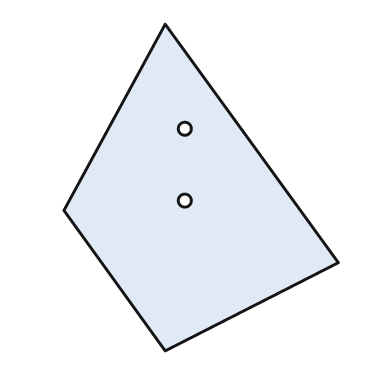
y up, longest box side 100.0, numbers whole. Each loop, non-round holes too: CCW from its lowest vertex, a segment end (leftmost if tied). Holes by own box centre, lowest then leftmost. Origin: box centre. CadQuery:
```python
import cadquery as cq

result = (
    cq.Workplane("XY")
    .moveTo(-11.0, -50.0)
    .lineTo(42.0, -23.0)
    .lineTo(-11.0, 50.0)
    .lineTo(-42.0, -7.0)
    .close()
    .moveTo(-5.0, -4.0)
    .circle(2.0)
    .moveTo(-5.0, 18.0)
    .circle(2.0)
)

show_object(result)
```